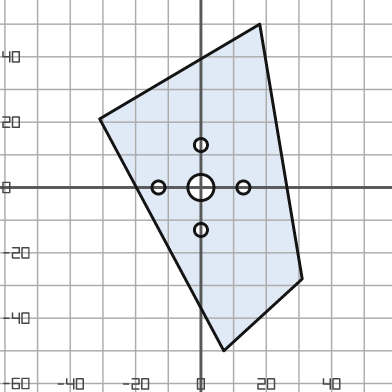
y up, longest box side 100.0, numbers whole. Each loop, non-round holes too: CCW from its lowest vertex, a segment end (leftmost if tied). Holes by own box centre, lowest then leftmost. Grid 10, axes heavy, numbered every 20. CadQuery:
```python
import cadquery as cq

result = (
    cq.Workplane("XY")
    .moveTo(7.0, -50.0)
    .lineTo(31.0, -28.0)
    .lineTo(18.0, 50.0)
    .lineTo(-31.0, 21.0)
    .close()
    .moveTo(0.0, -13.0)
    .circle(2.0)
    .moveTo(-13.0, 0.0)
    .circle(2.0)
    .moveTo(0.0, 0.0)
    .circle(4.0)
    .moveTo(13.0, 0.0)
    .circle(2.0)
    .moveTo(0.0, 13.0)
    .circle(2.0)
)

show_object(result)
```